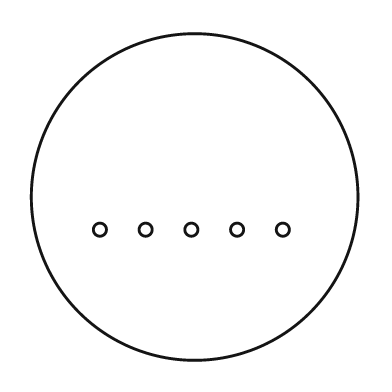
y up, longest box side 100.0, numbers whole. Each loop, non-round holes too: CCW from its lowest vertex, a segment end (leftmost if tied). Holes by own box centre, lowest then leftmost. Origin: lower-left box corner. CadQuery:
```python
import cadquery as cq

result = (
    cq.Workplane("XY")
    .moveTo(50.0, 50.0)
    .circle(50.0)
    .moveTo(21.0, 40.0)
    .circle(2.0)
    .moveTo(35.0, 40.0)
    .circle(2.0)
    .moveTo(49.0, 40.0)
    .circle(2.0)
    .moveTo(63.0, 40.0)
    .circle(2.0)
    .moveTo(77.0, 40.0)
    .circle(2.0)
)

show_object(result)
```